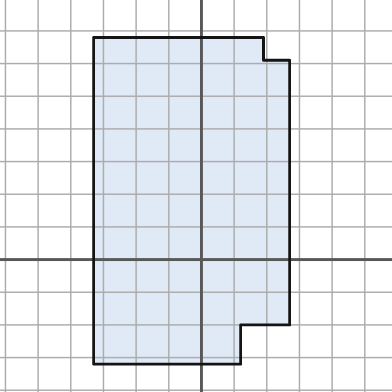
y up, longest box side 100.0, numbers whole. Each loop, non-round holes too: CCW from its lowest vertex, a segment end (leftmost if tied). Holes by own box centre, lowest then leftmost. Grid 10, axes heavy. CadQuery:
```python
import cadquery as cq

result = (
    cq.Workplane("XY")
    .moveTo(-33.0, -32.0)
    .lineTo(12.0, -32.0)
    .lineTo(12.0, -20.0)
    .lineTo(27.0, -20.0)
    .lineTo(27.0, 61.0)
    .lineTo(19.0, 61.0)
    .lineTo(19.0, 68.0)
    .lineTo(-33.0, 68.0)
    .close()
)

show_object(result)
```